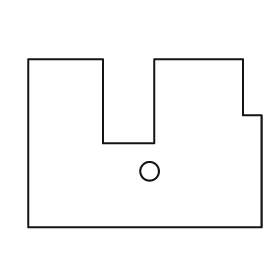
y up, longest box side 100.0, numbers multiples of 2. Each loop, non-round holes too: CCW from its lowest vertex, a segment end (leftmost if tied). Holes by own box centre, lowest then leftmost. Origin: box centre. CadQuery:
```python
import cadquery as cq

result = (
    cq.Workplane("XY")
    .moveTo(-50.0, -36.0)
    .lineTo(50.0, -36.0)
    .lineTo(50.0, 12.0)
    .lineTo(42.0, 12.0)
    .lineTo(42.0, 36.0)
    .lineTo(4.0, 36.0)
    .lineTo(4.0, 0.0)
    .lineTo(-18.0, 0.0)
    .lineTo(-18.0, 36.0)
    .lineTo(-50.0, 36.0)
    .close()
    .moveTo(2.0, -12.0)
    .circle(4.0)
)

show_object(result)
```